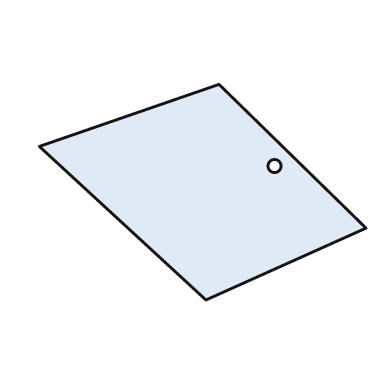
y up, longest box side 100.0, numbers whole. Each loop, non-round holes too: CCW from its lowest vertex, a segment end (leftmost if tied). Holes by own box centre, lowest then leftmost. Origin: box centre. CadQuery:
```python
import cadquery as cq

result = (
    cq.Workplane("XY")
    .moveTo(1.0, -33.0)
    .lineTo(50.0, -11.0)
    .lineTo(5.0, 33.0)
    .lineTo(-50.0, 14.0)
    .close()
    .moveTo(22.0, 8.0)
    .circle(2.0)
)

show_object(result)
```